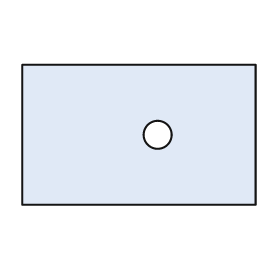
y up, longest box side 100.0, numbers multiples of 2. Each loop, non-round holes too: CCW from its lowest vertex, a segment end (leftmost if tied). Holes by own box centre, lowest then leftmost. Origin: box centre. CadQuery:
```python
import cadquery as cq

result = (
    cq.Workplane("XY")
    .moveTo(-50.0, -30.0)
    .lineTo(50.0, -30.0)
    .lineTo(50.0, 30.0)
    .lineTo(-50.0, 30.0)
    .close()
    .moveTo(8.0, 0.0)
    .circle(6.0)
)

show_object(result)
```